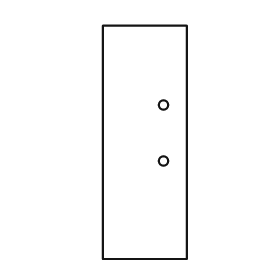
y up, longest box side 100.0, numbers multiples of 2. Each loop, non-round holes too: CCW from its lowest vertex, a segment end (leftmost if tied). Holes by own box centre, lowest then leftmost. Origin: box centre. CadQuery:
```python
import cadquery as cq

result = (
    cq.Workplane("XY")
    .moveTo(-18.0, -50.0)
    .lineTo(18.0, -50.0)
    .lineTo(18.0, 50.0)
    .lineTo(-18.0, 50.0)
    .close()
    .moveTo(8.0, -8.0)
    .circle(2.0)
    .moveTo(8.0, 16.0)
    .circle(2.0)
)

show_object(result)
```